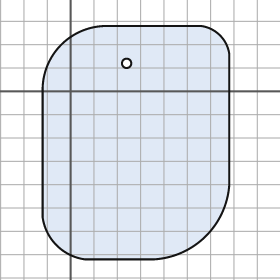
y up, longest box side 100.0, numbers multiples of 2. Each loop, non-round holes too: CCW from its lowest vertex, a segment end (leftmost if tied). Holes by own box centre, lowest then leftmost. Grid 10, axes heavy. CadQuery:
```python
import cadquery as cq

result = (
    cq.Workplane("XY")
    .moveTo(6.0, -72.0)
    .lineTo(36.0, -72.0)
    .threePointArc((58.0, -62.0), (68.0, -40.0))
    .lineTo(68.0, 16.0)
    .threePointArc((64.0, 24.0), (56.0, 28.0))
    .lineTo(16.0, 28.0)
    .threePointArc((-4.0, 20.0), (-12.0, 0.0))
    .lineTo(-12.0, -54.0)
    .threePointArc((-6.0, -66.0), (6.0, -72.0))
    .close()
    .moveTo(24.0, 12.0)
    .circle(2.0)
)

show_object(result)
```